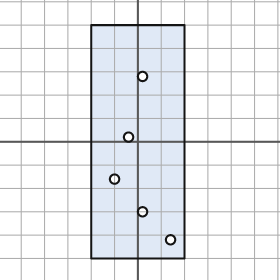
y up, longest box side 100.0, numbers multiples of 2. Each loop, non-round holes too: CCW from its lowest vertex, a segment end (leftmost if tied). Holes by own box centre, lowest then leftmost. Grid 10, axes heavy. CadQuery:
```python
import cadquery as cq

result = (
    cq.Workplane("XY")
    .moveTo(-20.0, -50.0)
    .lineTo(20.0, -50.0)
    .lineTo(20.0, 50.0)
    .lineTo(-20.0, 50.0)
    .close()
    .moveTo(14.0, -42.0)
    .circle(2.0)
    .moveTo(2.0, -30.0)
    .circle(2.0)
    .moveTo(-10.0, -16.0)
    .circle(2.0)
    .moveTo(-4.0, 2.0)
    .circle(2.0)
    .moveTo(2.0, 28.0)
    .circle(2.0)
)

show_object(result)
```